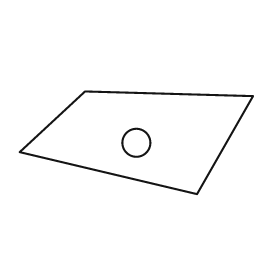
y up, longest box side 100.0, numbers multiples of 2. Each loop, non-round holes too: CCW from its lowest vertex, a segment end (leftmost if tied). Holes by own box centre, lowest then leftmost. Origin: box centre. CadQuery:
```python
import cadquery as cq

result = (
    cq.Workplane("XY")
    .moveTo(26.0, -22.0)
    .lineTo(50.0, 20.0)
    .lineTo(-22.0, 22.0)
    .lineTo(-50.0, -4.0)
    .close()
    .moveTo(0.0, 0.0)
    .circle(6.0)
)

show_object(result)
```